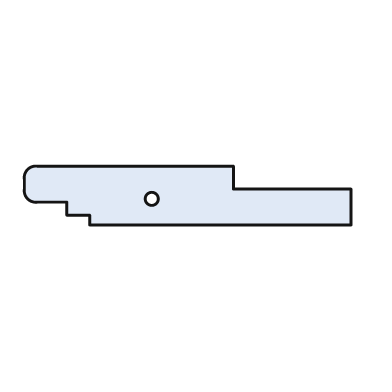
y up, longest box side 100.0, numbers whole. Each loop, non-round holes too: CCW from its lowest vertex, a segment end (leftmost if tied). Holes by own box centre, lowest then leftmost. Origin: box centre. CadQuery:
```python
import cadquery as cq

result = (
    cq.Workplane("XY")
    .moveTo(-30.0, -9.0)
    .lineTo(50.0, -9.0)
    .lineTo(50.0, 2.0)
    .lineTo(14.0, 2.0)
    .lineTo(14.0, 9.0)
    .lineTo(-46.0, 9.0)
    .threePointArc((-49.0, 8.0), (-50.0, 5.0))
    .lineTo(-50.0, 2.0)
    .threePointArc((-49.0, -1.0), (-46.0, -2.0))
    .lineTo(-37.0, -2.0)
    .lineTo(-37.0, -6.0)
    .lineTo(-30.0, -6.0)
    .close()
    .moveTo(-11.0, -1.0)
    .circle(2.0)
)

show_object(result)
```